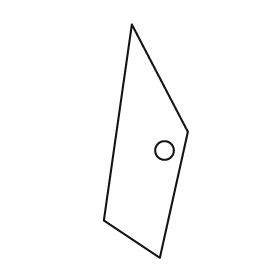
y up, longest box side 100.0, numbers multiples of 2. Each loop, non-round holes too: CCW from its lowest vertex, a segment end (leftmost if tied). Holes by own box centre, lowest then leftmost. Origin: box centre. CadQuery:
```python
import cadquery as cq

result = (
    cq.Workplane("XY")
    .moveTo(6.0, -50.0)
    .lineTo(18.0, 4.0)
    .lineTo(-6.0, 50.0)
    .lineTo(-18.0, -34.0)
    .close()
    .moveTo(8.0, -4.0)
    .circle(4.0)
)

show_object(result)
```